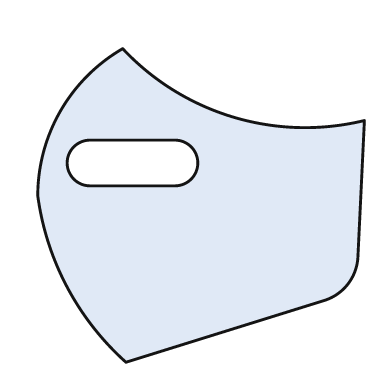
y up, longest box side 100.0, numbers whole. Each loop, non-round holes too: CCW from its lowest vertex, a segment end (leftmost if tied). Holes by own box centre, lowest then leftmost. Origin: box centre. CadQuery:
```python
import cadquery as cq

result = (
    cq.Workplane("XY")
    .moveTo(-23.0, -48.0)
    .lineTo(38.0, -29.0)
    .threePointArc((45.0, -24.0), (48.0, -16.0))
    .lineTo(50.0, 26.0)
    .threePointArc((10.0, 27.0), (-24.0, 48.0))
    .threePointArc((-43.0, 29.0), (-50.0, 3.0))
    .threePointArc((-41.0, -25.0), (-23.0, -48.0))
    .close()
    .moveTo(-34.0, 6.0)
    .lineTo(-8.0, 6.0)
    .threePointArc((-1.0, 13.0), (-8.0, 20.0))
    .lineTo(-34.0, 20.0)
    .threePointArc((-41.0, 13.0), (-34.0, 6.0))
    .close()
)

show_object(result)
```